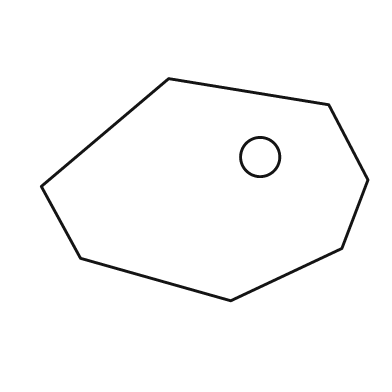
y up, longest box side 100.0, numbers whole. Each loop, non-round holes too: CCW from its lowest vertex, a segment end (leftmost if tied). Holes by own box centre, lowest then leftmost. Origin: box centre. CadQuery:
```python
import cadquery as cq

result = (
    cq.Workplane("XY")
    .moveTo(8.0, -34.0)
    .lineTo(42.0, -18.0)
    .lineTo(50.0, 3.0)
    .lineTo(38.0, 26.0)
    .lineTo(-11.0, 34.0)
    .lineTo(-50.0, 1.0)
    .lineTo(-38.0, -21.0)
    .close()
    .moveTo(17.0, 10.0)
    .circle(6.0)
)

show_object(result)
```